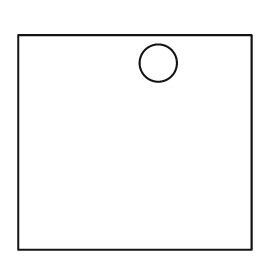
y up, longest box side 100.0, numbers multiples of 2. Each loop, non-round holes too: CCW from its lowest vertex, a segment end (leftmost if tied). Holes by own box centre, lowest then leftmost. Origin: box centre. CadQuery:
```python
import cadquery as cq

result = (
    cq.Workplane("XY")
    .moveTo(-50.0, -46.0)
    .lineTo(50.0, -46.0)
    .lineTo(50.0, 46.0)
    .lineTo(-50.0, 46.0)
    .close()
    .moveTo(10.0, 34.0)
    .circle(8.0)
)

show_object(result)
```